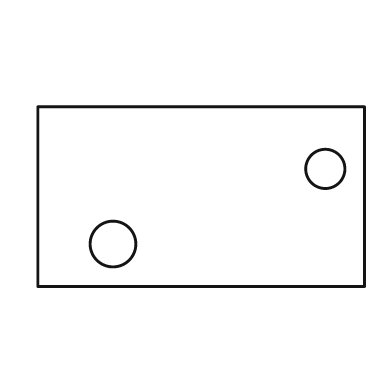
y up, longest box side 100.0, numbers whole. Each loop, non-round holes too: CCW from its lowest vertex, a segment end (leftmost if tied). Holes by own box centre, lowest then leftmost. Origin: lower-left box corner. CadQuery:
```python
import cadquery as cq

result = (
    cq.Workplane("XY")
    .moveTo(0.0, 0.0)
    .lineTo(100.0, 0.0)
    .lineTo(100.0, 55.0)
    .lineTo(0.0, 55.0)
    .close()
    .moveTo(23.0, 13.0)
    .circle(7.0)
    .moveTo(88.0, 36.0)
    .circle(6.0)
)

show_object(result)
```